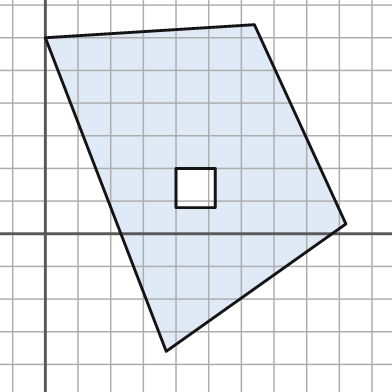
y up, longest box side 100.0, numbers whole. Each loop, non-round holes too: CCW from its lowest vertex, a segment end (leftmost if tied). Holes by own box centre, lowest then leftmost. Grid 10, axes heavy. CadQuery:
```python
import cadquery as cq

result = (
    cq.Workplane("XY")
    .moveTo(37.0, -36.0)
    .lineTo(92.0, 3.0)
    .lineTo(64.0, 64.0)
    .lineTo(0.0, 60.0)
    .close()
    .moveTo(40.0, 8.0)
    .lineTo(52.0, 8.0)
    .lineTo(52.0, 20.0)
    .lineTo(40.0, 20.0)
    .close()
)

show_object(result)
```